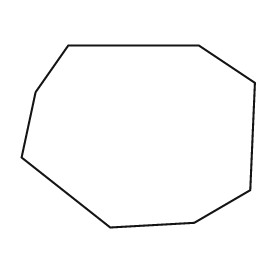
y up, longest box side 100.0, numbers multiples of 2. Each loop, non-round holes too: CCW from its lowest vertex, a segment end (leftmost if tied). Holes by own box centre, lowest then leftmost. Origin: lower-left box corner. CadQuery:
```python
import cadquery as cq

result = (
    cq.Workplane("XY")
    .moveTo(38.0, 0.0)
    .lineTo(74.0, 2.0)
    .lineTo(98.0, 16.0)
    .lineTo(100.0, 62.0)
    .lineTo(76.0, 78.0)
    .lineTo(20.0, 78.0)
    .lineTo(6.0, 58.0)
    .lineTo(0.0, 30.0)
    .close()
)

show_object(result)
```